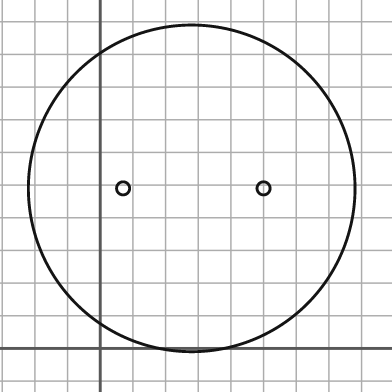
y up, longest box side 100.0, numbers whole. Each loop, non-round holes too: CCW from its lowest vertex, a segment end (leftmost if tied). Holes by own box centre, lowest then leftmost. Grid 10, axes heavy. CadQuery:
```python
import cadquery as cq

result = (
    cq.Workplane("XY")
    .moveTo(28.0, 49.0)
    .circle(50.0)
    .moveTo(7.0, 49.0)
    .circle(2.0)
    .moveTo(50.0, 49.0)
    .circle(2.0)
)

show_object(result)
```